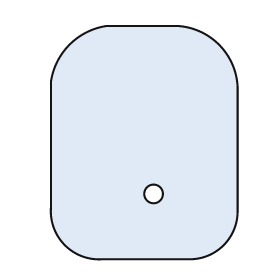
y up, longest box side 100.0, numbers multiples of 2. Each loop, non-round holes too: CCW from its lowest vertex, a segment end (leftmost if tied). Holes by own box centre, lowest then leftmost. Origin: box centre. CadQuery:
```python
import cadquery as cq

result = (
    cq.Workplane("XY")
    .moveTo(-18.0, -50.0)
    .lineTo(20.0, -50.0)
    .threePointArc((34.0, -44.0), (40.0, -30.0))
    .lineTo(40.0, 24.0)
    .threePointArc((32.0, 42.0), (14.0, 50.0))
    .lineTo(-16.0, 50.0)
    .threePointArc((-32.0, 42.0), (-40.0, 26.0))
    .lineTo(-40.0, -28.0)
    .threePointArc((-34.0, -44.0), (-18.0, -50.0))
    .close()
    .moveTo(4.0, -22.0)
    .circle(4.0)
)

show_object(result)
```